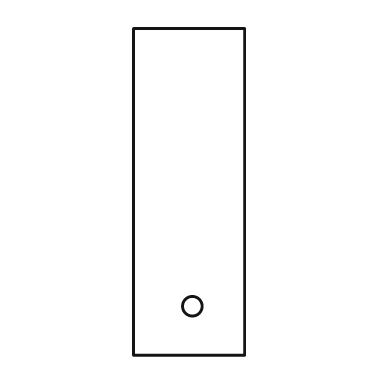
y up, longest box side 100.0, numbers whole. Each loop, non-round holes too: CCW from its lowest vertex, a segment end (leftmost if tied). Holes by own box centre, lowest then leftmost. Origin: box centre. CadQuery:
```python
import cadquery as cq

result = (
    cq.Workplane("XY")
    .moveTo(-17.0, -50.0)
    .lineTo(17.0, -50.0)
    .lineTo(17.0, 50.0)
    .lineTo(-17.0, 50.0)
    .close()
    .moveTo(1.0, -35.0)
    .circle(3.0)
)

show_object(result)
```